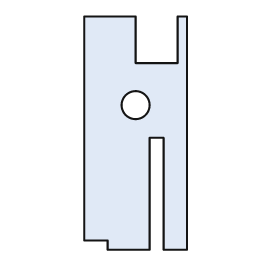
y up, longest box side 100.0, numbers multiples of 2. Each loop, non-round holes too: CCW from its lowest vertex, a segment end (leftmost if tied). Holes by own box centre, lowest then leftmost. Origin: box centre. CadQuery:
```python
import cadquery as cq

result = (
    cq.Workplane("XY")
    .moveTo(-12.0, -50.0)
    .lineTo(6.0, -50.0)
    .lineTo(6.0, -2.0)
    .lineTo(12.0, -2.0)
    .lineTo(12.0, -50.0)
    .lineTo(22.0, -50.0)
    .lineTo(22.0, 50.0)
    .lineTo(18.0, 50.0)
    .lineTo(18.0, 30.0)
    .lineTo(0.0, 30.0)
    .lineTo(0.0, 50.0)
    .lineTo(-22.0, 50.0)
    .lineTo(-22.0, -46.0)
    .lineTo(-12.0, -46.0)
    .close()
    .moveTo(0.0, 12.0)
    .circle(6.0)
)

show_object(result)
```